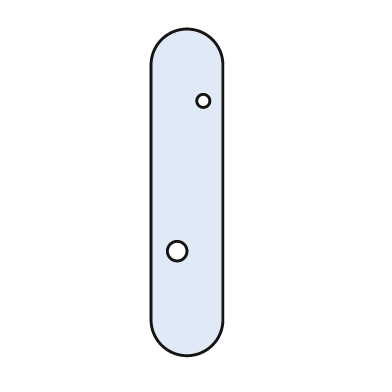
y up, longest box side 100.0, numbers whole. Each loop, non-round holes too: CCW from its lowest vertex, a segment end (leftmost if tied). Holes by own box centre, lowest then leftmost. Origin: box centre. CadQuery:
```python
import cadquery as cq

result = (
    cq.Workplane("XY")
    .moveTo(-11.0, -39.0)
    .threePointArc((0.0, -50.0), (11.0, -39.0))
    .lineTo(11.0, 39.0)
    .threePointArc((0.0, 50.0), (-11.0, 39.0))
    .close()
    .moveTo(-3.0, -18.0)
    .circle(3.0)
    .moveTo(5.0, 28.0)
    .circle(2.0)
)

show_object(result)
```